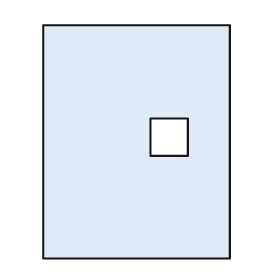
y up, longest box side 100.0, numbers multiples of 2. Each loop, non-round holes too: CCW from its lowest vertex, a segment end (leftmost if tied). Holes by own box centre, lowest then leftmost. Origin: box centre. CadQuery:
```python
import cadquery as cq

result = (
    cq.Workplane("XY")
    .moveTo(-40.0, -50.0)
    .lineTo(40.0, -50.0)
    .lineTo(40.0, 50.0)
    .lineTo(-40.0, 50.0)
    .close()
    .moveTo(6.0, -6.0)
    .lineTo(22.0, -6.0)
    .lineTo(22.0, 10.0)
    .lineTo(6.0, 10.0)
    .close()
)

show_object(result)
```